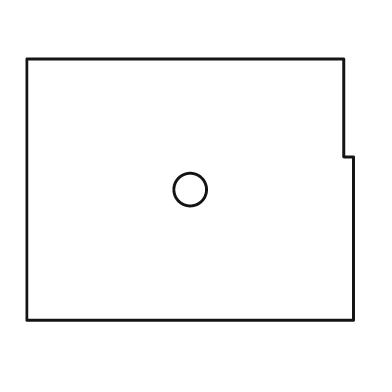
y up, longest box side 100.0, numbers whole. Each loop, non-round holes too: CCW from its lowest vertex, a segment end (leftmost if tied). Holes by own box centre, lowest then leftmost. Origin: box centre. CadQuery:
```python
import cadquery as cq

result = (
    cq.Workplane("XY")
    .moveTo(-50.0, -40.0)
    .lineTo(50.0, -40.0)
    .lineTo(50.0, 10.0)
    .lineTo(47.0, 10.0)
    .lineTo(47.0, 40.0)
    .lineTo(-50.0, 40.0)
    .close()
    .moveTo(0.0, 0.0)
    .circle(5.0)
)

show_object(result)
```